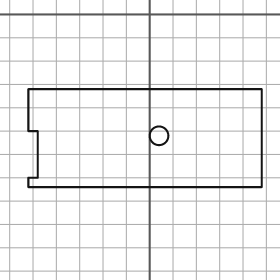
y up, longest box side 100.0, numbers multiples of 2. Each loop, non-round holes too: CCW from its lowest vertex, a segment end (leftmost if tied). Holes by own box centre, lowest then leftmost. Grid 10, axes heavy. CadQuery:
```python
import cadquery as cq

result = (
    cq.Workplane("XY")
    .moveTo(-52.0, -74.0)
    .lineTo(48.0, -74.0)
    .lineTo(48.0, -32.0)
    .lineTo(-52.0, -32.0)
    .lineTo(-52.0, -50.0)
    .lineTo(-48.0, -50.0)
    .lineTo(-48.0, -70.0)
    .lineTo(-52.0, -70.0)
    .close()
    .moveTo(4.0, -52.0)
    .circle(4.0)
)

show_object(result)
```